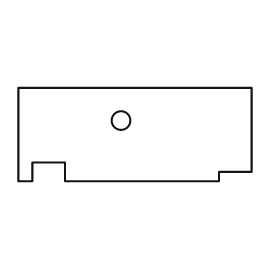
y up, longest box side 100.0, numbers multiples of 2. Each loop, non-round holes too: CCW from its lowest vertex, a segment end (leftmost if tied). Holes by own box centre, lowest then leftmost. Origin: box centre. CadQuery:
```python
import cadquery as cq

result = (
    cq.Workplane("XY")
    .moveTo(-50.0, -20.0)
    .lineTo(-44.0, -20.0)
    .lineTo(-44.0, -12.0)
    .lineTo(-30.0, -12.0)
    .lineTo(-30.0, -20.0)
    .lineTo(36.0, -20.0)
    .lineTo(36.0, -16.0)
    .lineTo(50.0, -16.0)
    .lineTo(50.0, 20.0)
    .lineTo(-50.0, 20.0)
    .close()
    .moveTo(-6.0, 6.0)
    .circle(4.0)
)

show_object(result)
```